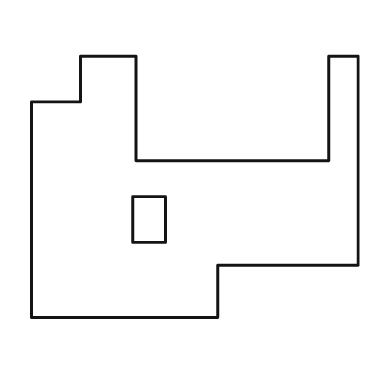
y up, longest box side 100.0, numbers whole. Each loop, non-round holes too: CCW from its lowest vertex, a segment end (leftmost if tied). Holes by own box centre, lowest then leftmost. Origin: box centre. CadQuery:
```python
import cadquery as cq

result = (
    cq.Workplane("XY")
    .moveTo(-50.0, -40.0)
    .lineTo(7.0, -40.0)
    .lineTo(7.0, -24.0)
    .lineTo(50.0, -24.0)
    .lineTo(50.0, 40.0)
    .lineTo(41.0, 40.0)
    .lineTo(41.0, 8.0)
    .lineTo(-18.0, 8.0)
    .lineTo(-18.0, 40.0)
    .lineTo(-35.0, 40.0)
    .lineTo(-35.0, 26.0)
    .lineTo(-50.0, 26.0)
    .close()
    .moveTo(-19.0, -17.0)
    .lineTo(-9.0, -17.0)
    .lineTo(-9.0, -3.0)
    .lineTo(-19.0, -3.0)
    .close()
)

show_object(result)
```